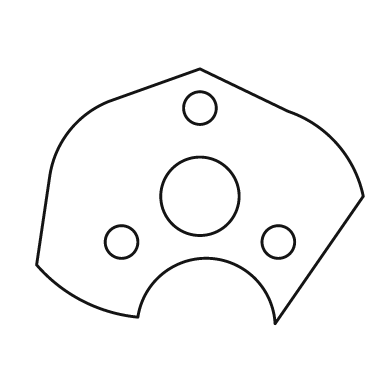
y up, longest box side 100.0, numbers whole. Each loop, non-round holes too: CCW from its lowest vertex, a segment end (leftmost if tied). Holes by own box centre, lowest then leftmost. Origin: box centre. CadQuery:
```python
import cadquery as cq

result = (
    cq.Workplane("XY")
    .moveTo(23.0, -39.0)
    .lineTo(50.0, 0.0)
    .threePointArc((42.0, 16.0), (27.0, 26.0))
    .lineTo(0.0, 39.0)
    .lineTo(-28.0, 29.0)
    .threePointArc((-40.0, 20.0), (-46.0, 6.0))
    .lineTo(-50.0, -21.0)
    .threePointArc((-36.0, -32.0), (-19.0, -37.0))
    .threePointArc((3.0, -19.0), (23.0, -39.0))
    .close()
    .moveTo(-24.0, -14.0)
    .circle(5.0)
    .moveTo(24.0, -14.0)
    .circle(5.0)
    .moveTo(0.0, 0.0)
    .circle(12.0)
    .moveTo(0.0, 27.0)
    .circle(5.0)
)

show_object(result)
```